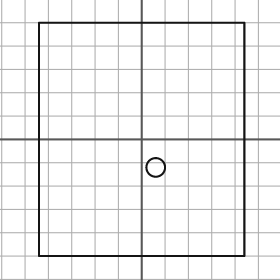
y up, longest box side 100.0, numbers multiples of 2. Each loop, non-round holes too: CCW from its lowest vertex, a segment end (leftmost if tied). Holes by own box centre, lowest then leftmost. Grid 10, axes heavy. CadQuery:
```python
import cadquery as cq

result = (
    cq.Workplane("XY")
    .moveTo(-44.0, -50.0)
    .lineTo(44.0, -50.0)
    .lineTo(44.0, 50.0)
    .lineTo(-44.0, 50.0)
    .close()
    .moveTo(6.0, -12.0)
    .circle(4.0)
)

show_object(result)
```